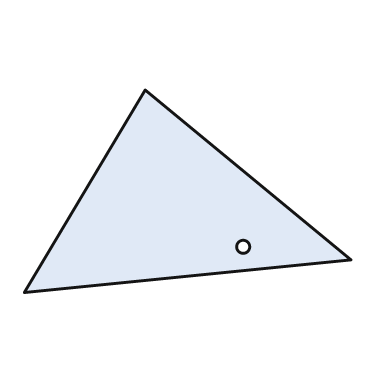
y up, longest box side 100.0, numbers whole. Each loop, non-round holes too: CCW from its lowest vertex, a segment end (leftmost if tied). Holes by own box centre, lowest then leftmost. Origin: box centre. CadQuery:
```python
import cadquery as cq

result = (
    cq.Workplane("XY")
    .moveTo(-50.0, -31.0)
    .lineTo(50.0, -21.0)
    .lineTo(-13.0, 31.0)
    .close()
    .moveTo(17.0, -17.0)
    .circle(2.0)
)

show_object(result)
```